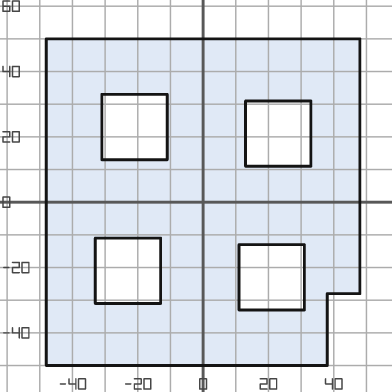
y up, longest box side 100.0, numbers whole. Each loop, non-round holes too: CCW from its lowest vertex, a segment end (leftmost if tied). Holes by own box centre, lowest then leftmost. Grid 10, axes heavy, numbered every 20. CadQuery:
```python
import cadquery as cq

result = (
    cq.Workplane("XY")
    .moveTo(-48.0, -50.0)
    .lineTo(38.0, -50.0)
    .lineTo(38.0, -28.0)
    .lineTo(48.0, -28.0)
    .lineTo(48.0, 50.0)
    .lineTo(-48.0, 50.0)
    .close()
    .moveTo(11.0, -33.0)
    .lineTo(31.0, -33.0)
    .lineTo(31.0, -13.0)
    .lineTo(11.0, -13.0)
    .close()
    .moveTo(-33.0, -31.0)
    .lineTo(-13.0, -31.0)
    .lineTo(-13.0, -11.0)
    .lineTo(-33.0, -11.0)
    .close()
    .moveTo(13.0, 11.0)
    .lineTo(33.0, 11.0)
    .lineTo(33.0, 31.0)
    .lineTo(13.0, 31.0)
    .close()
    .moveTo(-31.0, 13.0)
    .lineTo(-11.0, 13.0)
    .lineTo(-11.0, 33.0)
    .lineTo(-31.0, 33.0)
    .close()
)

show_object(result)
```